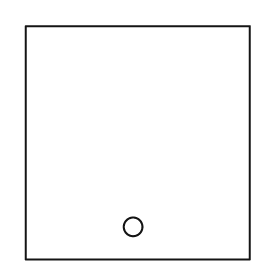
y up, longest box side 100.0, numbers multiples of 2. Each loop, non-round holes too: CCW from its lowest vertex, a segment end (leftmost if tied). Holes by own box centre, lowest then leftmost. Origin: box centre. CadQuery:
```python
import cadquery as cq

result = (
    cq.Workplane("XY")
    .moveTo(-48.0, -50.0)
    .lineTo(48.0, -50.0)
    .lineTo(48.0, 50.0)
    .lineTo(-48.0, 50.0)
    .close()
    .moveTo(-2.0, -36.0)
    .circle(4.0)
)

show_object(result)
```